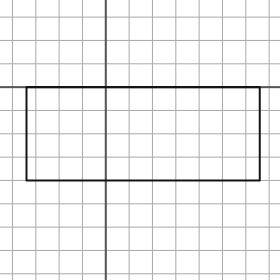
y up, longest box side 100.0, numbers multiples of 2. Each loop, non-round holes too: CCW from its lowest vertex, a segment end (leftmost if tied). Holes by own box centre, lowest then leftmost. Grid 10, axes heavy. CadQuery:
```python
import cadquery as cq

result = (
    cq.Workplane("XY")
    .moveTo(-34.0, -40.0)
    .lineTo(66.0, -40.0)
    .lineTo(66.0, 0.0)
    .lineTo(-34.0, 0.0)
    .close()
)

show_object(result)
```